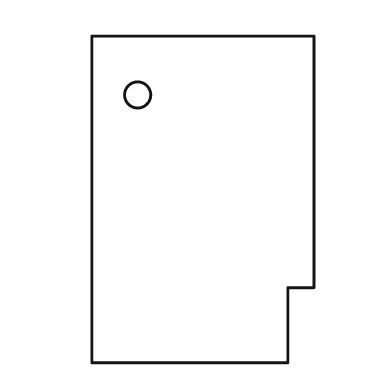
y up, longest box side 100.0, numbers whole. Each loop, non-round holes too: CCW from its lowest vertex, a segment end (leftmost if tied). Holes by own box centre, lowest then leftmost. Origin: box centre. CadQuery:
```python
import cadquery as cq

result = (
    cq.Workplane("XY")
    .moveTo(-34.0, -50.0)
    .lineTo(26.0, -50.0)
    .lineTo(26.0, -27.0)
    .lineTo(34.0, -27.0)
    .lineTo(34.0, 50.0)
    .lineTo(-34.0, 50.0)
    .close()
    .moveTo(-20.0, 32.0)
    .circle(4.0)
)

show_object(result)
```